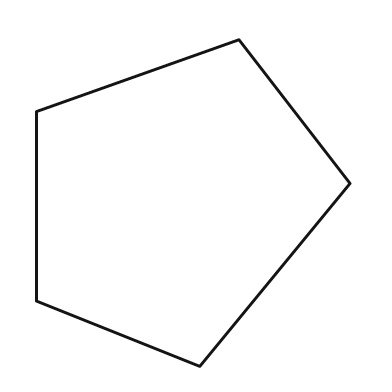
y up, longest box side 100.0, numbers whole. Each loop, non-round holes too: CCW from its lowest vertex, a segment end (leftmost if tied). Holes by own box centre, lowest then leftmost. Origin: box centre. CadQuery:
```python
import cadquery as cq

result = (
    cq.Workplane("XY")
    .moveTo(2.0, -50.0)
    .lineTo(48.0, 6.0)
    .lineTo(14.0, 50.0)
    .lineTo(-48.0, 28.0)
    .lineTo(-48.0, -30.0)
    .close()
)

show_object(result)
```